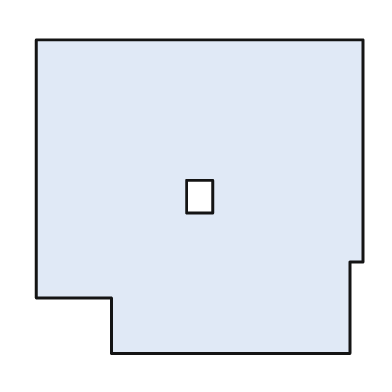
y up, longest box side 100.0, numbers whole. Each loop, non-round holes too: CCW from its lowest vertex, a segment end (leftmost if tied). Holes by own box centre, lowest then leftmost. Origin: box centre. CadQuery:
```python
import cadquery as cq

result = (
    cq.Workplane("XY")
    .moveTo(-27.0, -48.0)
    .lineTo(46.0, -48.0)
    .lineTo(46.0, -20.0)
    .lineTo(50.0, -20.0)
    .lineTo(50.0, 48.0)
    .lineTo(-50.0, 48.0)
    .lineTo(-50.0, -31.0)
    .lineTo(-27.0, -31.0)
    .close()
    .moveTo(-4.0, -5.0)
    .lineTo(4.0, -5.0)
    .lineTo(4.0, 5.0)
    .lineTo(-4.0, 5.0)
    .close()
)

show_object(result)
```